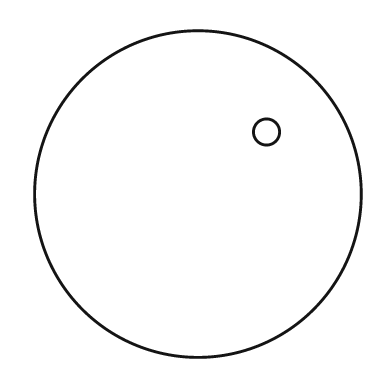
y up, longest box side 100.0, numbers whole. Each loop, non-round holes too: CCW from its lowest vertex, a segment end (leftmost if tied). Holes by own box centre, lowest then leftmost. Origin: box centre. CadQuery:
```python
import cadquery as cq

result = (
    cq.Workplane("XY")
    .moveTo(0.0, 0.0)
    .circle(50.0)
    .moveTo(21.0, 19.0)
    .circle(4.0)
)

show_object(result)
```